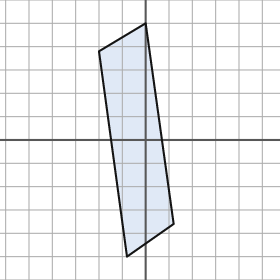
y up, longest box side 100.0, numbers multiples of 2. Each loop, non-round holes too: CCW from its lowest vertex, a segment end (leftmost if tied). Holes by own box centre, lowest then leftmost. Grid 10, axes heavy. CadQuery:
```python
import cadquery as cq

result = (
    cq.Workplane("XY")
    .moveTo(-8.0, -50.0)
    .lineTo(12.0, -36.0)
    .lineTo(0.0, 50.0)
    .lineTo(-20.0, 38.0)
    .close()
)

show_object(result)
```